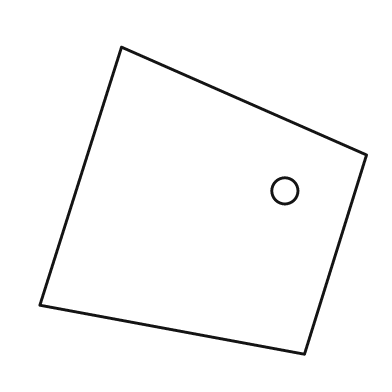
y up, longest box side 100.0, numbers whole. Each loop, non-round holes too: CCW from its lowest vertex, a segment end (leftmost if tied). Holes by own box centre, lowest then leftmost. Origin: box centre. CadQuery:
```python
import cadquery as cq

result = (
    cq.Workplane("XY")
    .moveTo(31.0, -47.0)
    .lineTo(50.0, 14.0)
    .lineTo(-25.0, 47.0)
    .lineTo(-50.0, -32.0)
    .close()
    .moveTo(25.0, 3.0)
    .circle(4.0)
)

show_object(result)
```